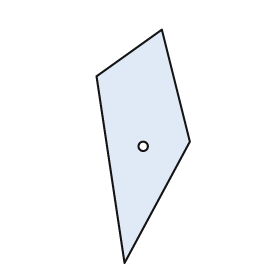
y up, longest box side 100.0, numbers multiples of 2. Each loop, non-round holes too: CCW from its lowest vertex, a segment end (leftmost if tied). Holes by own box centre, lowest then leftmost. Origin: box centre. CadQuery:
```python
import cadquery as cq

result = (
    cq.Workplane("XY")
    .moveTo(-8.0, -50.0)
    .lineTo(20.0, 2.0)
    .lineTo(8.0, 50.0)
    .lineTo(-20.0, 30.0)
    .close()
    .moveTo(0.0, 0.0)
    .circle(2.0)
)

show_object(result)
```